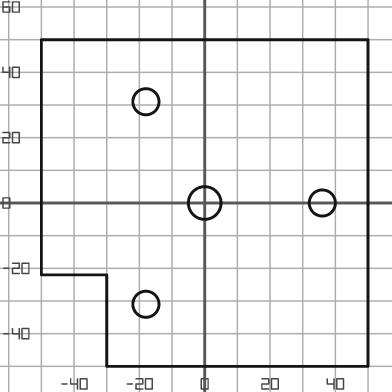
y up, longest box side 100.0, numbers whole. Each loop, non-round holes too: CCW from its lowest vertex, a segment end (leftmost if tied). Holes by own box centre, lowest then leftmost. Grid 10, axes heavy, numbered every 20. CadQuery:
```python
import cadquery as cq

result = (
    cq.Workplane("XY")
    .moveTo(-30.0, -50.0)
    .lineTo(50.0, -50.0)
    .lineTo(50.0, 50.0)
    .lineTo(-50.0, 50.0)
    .lineTo(-50.0, -22.0)
    .lineTo(-30.0, -22.0)
    .close()
    .moveTo(-18.0, -31.0)
    .circle(4.0)
    .moveTo(0.0, 0.0)
    .circle(5.0)
    .moveTo(36.0, 0.0)
    .circle(4.0)
    .moveTo(-18.0, 31.0)
    .circle(4.0)
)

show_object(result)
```